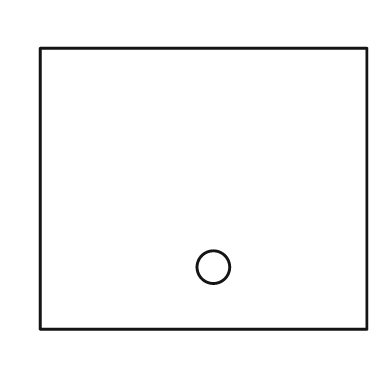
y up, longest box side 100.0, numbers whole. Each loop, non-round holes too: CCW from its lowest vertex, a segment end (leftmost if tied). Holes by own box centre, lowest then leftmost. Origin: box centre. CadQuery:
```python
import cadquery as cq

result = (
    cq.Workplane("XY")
    .moveTo(-50.0, -43.0)
    .lineTo(50.0, -43.0)
    .lineTo(50.0, 43.0)
    .lineTo(-50.0, 43.0)
    .close()
    .moveTo(3.0, -24.0)
    .circle(5.0)
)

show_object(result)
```